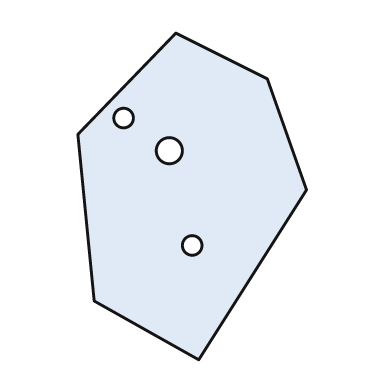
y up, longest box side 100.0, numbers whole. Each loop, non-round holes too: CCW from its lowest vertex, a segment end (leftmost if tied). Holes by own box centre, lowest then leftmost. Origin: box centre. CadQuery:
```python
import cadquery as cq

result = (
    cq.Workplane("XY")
    .moveTo(2.0, -50.0)
    .lineTo(35.0, 2.0)
    .lineTo(23.0, 36.0)
    .lineTo(-5.0, 50.0)
    .lineTo(-35.0, 19.0)
    .lineTo(-30.0, -32.0)
    .close()
    .moveTo(0.0, -15.0)
    .circle(3.0)
    .moveTo(-7.0, 14.0)
    .circle(4.0)
    .moveTo(-21.0, 24.0)
    .circle(3.0)
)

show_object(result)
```